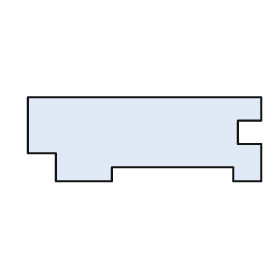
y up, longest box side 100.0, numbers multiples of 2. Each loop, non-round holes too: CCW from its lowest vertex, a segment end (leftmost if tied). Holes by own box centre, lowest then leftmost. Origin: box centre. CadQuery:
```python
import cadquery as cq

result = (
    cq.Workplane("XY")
    .moveTo(-38.0, -18.0)
    .lineTo(-14.0, -18.0)
    .lineTo(-14.0, -12.0)
    .lineTo(38.0, -12.0)
    .lineTo(38.0, -18.0)
    .lineTo(50.0, -18.0)
    .lineTo(50.0, -2.0)
    .lineTo(40.0, -2.0)
    .lineTo(40.0, 8.0)
    .lineTo(50.0, 8.0)
    .lineTo(50.0, 18.0)
    .lineTo(-50.0, 18.0)
    .lineTo(-50.0, -6.0)
    .lineTo(-38.0, -6.0)
    .close()
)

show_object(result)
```